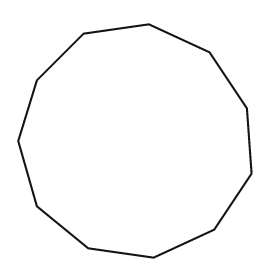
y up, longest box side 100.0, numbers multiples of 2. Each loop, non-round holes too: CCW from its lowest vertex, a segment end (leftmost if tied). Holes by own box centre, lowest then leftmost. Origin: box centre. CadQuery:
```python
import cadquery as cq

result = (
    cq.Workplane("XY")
    .moveTo(8.0, -50.0)
    .lineTo(34.0, -38.0)
    .lineTo(50.0, -14.0)
    .lineTo(48.0, 14.0)
    .lineTo(32.0, 38.0)
    .lineTo(6.0, 50.0)
    .lineTo(-22.0, 46.0)
    .lineTo(-42.0, 26.0)
    .lineTo(-50.0, 0.0)
    .lineTo(-42.0, -28.0)
    .lineTo(-20.0, -46.0)
    .close()
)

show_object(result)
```